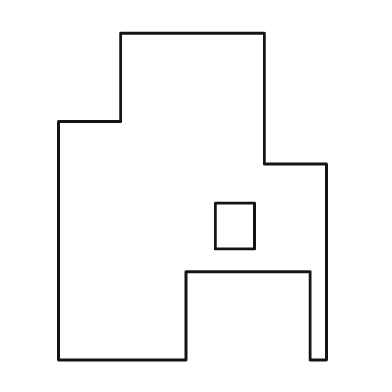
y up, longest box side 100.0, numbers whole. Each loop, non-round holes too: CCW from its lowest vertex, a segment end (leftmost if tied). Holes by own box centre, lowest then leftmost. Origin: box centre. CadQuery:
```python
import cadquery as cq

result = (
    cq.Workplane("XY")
    .moveTo(-41.0, -50.0)
    .lineTo(-2.0, -50.0)
    .lineTo(-2.0, -23.0)
    .lineTo(36.0, -23.0)
    .lineTo(36.0, -50.0)
    .lineTo(41.0, -50.0)
    .lineTo(41.0, 10.0)
    .lineTo(22.0, 10.0)
    .lineTo(22.0, 50.0)
    .lineTo(-22.0, 50.0)
    .lineTo(-22.0, 23.0)
    .lineTo(-41.0, 23.0)
    .close()
    .moveTo(7.0, -16.0)
    .lineTo(19.0, -16.0)
    .lineTo(19.0, -2.0)
    .lineTo(7.0, -2.0)
    .close()
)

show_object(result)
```